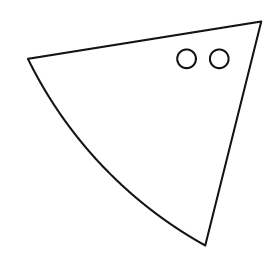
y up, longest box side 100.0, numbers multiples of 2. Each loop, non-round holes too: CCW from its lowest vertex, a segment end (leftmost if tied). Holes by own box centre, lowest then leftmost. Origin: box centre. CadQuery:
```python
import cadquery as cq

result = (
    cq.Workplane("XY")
    .moveTo(26.0, -48.0)
    .lineTo(50.0, 48.0)
    .lineTo(-50.0, 32.0)
    .threePointArc((-18.0, -14.0), (26.0, -48.0))
    .close()
    .moveTo(18.0, 32.0)
    .circle(4.0)
    .moveTo(32.0, 32.0)
    .circle(4.0)
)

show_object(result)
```